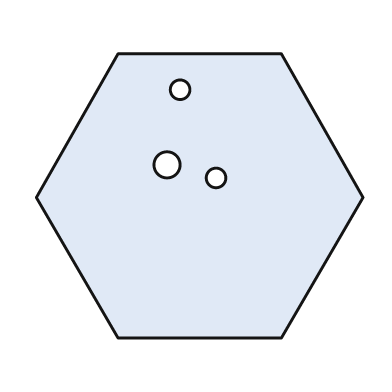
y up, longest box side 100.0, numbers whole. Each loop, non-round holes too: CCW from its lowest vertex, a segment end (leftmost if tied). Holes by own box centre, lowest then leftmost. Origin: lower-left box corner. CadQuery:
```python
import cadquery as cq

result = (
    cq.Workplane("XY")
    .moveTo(25.0, 0.0)
    .lineTo(75.0, 0.0)
    .lineTo(100.0, 43.0)
    .lineTo(75.0, 87.0)
    .lineTo(25.0, 87.0)
    .lineTo(0.0, 43.0)
    .close()
    .moveTo(55.0, 49.0)
    .circle(3.0)
    .moveTo(40.0, 53.0)
    .circle(4.0)
    .moveTo(44.0, 76.0)
    .circle(3.0)
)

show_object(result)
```